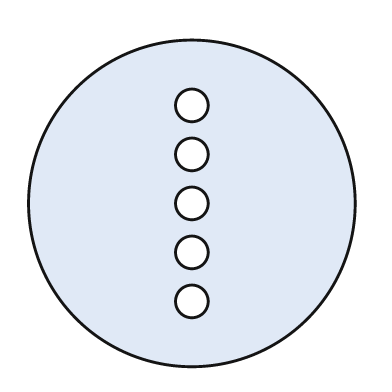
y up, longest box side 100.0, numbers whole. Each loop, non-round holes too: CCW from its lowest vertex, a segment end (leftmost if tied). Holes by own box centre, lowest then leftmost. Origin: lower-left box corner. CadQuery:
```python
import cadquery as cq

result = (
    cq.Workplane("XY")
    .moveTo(50.0, 50.0)
    .circle(50.0)
    .moveTo(50.0, 20.0)
    .circle(5.0)
    .moveTo(50.0, 35.0)
    .circle(5.0)
    .moveTo(50.0, 50.0)
    .circle(5.0)
    .moveTo(50.0, 65.0)
    .circle(5.0)
    .moveTo(50.0, 80.0)
    .circle(5.0)
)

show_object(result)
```